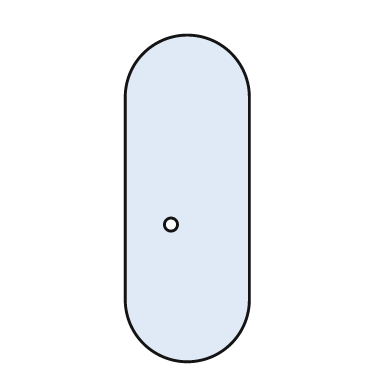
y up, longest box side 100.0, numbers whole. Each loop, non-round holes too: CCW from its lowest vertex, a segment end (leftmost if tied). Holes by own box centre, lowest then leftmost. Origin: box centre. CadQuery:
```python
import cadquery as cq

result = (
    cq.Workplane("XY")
    .moveTo(-19.0, -31.0)
    .threePointArc((0.0, -50.0), (19.0, -31.0))
    .lineTo(19.0, 31.0)
    .threePointArc((0.0, 50.0), (-19.0, 31.0))
    .close()
    .moveTo(-5.0, -8.0)
    .circle(2.0)
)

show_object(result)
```